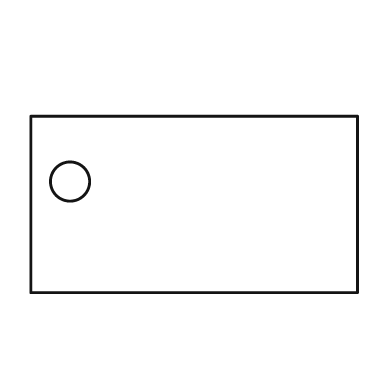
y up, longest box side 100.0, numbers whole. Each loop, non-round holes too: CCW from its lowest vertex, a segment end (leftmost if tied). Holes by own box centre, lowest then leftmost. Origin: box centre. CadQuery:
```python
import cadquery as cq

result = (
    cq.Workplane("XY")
    .moveTo(-50.0, -27.0)
    .lineTo(50.0, -27.0)
    .lineTo(50.0, 27.0)
    .lineTo(-50.0, 27.0)
    .close()
    .moveTo(-38.0, 7.0)
    .circle(6.0)
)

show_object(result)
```